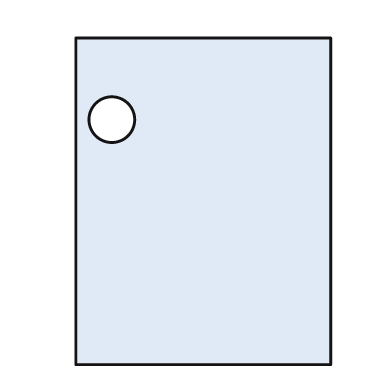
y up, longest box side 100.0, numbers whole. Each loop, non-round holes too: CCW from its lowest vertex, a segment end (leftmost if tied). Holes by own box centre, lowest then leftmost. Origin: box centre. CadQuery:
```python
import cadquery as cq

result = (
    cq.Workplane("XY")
    .moveTo(-39.0, -50.0)
    .lineTo(39.0, -50.0)
    .lineTo(39.0, 50.0)
    .lineTo(-39.0, 50.0)
    .close()
    .moveTo(-28.0, 25.0)
    .circle(7.0)
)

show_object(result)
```